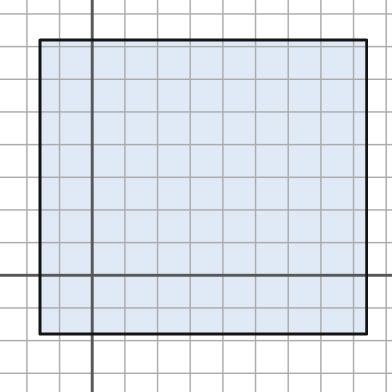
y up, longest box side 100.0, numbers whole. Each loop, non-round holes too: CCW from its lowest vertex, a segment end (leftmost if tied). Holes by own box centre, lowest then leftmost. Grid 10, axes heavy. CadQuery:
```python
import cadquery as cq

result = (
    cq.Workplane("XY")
    .moveTo(-16.0, -18.0)
    .lineTo(84.0, -18.0)
    .lineTo(84.0, 72.0)
    .lineTo(-16.0, 72.0)
    .close()
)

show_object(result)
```